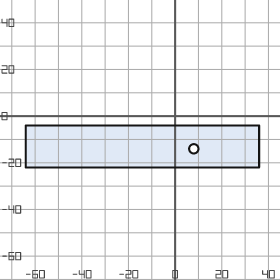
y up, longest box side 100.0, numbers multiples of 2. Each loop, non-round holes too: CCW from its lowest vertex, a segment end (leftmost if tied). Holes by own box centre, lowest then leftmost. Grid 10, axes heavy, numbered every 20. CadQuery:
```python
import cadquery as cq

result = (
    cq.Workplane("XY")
    .moveTo(-64.0, -22.0)
    .lineTo(36.0, -22.0)
    .lineTo(36.0, -4.0)
    .lineTo(-64.0, -4.0)
    .close()
    .moveTo(8.0, -14.0)
    .circle(2.0)
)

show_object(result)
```